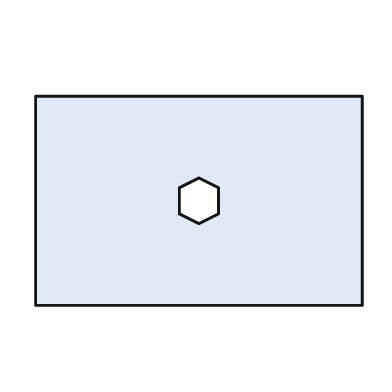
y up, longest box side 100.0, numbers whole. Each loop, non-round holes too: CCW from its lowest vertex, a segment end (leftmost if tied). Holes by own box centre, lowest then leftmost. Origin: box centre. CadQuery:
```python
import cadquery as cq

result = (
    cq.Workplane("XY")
    .moveTo(-50.0, -32.0)
    .lineTo(50.0, -32.0)
    .lineTo(50.0, 32.0)
    .lineTo(-50.0, 32.0)
    .close()
    .moveTo(0.0, -7.0)
    .lineTo(6.0, -4.0)
    .lineTo(6.0, 4.0)
    .lineTo(0.0, 7.0)
    .lineTo(-6.0, 4.0)
    .lineTo(-6.0, -4.0)
    .close()
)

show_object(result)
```